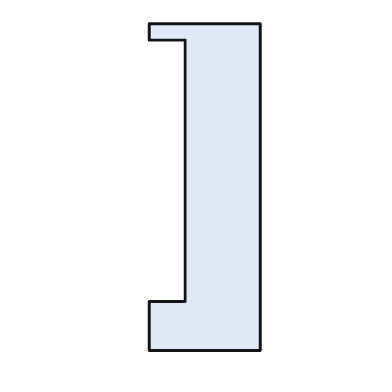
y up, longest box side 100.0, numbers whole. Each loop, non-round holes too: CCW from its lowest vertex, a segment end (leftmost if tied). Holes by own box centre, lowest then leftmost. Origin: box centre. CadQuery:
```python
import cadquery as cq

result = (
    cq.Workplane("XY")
    .moveTo(-17.0, -50.0)
    .lineTo(17.0, -50.0)
    .lineTo(17.0, 50.0)
    .lineTo(-17.0, 50.0)
    .lineTo(-17.0, 45.0)
    .lineTo(-6.0, 45.0)
    .lineTo(-6.0, -35.0)
    .lineTo(-17.0, -35.0)
    .close()
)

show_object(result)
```